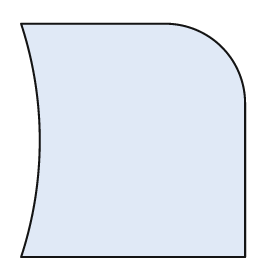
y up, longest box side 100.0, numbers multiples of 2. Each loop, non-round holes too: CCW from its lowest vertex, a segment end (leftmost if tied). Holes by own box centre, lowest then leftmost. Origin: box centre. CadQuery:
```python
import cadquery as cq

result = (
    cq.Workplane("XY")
    .moveTo(-48.0, -50.0)
    .lineTo(48.0, -50.0)
    .lineTo(48.0, 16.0)
    .threePointArc((38.0, 40.0), (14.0, 50.0))
    .lineTo(-48.0, 50.0)
    .threePointArc((-40.0, 0.0), (-48.0, -50.0))
    .close()
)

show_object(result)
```